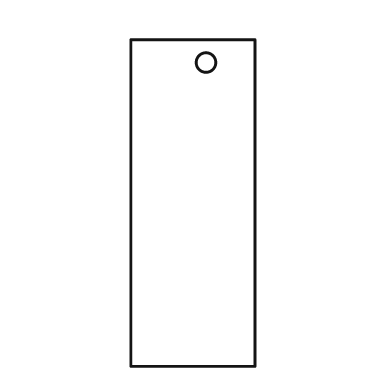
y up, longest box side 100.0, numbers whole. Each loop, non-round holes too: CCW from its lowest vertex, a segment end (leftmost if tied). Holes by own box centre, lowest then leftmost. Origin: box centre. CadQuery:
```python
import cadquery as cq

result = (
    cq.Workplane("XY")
    .moveTo(-19.0, -50.0)
    .lineTo(19.0, -50.0)
    .lineTo(19.0, 50.0)
    .lineTo(-19.0, 50.0)
    .close()
    .moveTo(4.0, 43.0)
    .circle(3.0)
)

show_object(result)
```